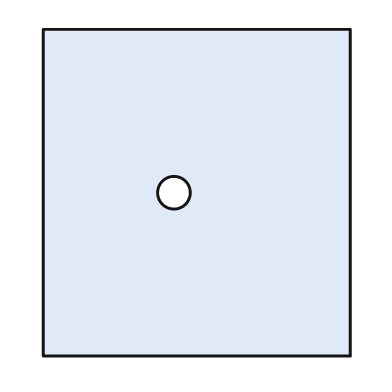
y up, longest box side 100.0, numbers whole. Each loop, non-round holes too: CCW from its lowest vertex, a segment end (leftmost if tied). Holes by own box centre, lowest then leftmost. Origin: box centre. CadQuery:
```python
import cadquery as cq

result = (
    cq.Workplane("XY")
    .moveTo(-47.0, -50.0)
    .lineTo(47.0, -50.0)
    .lineTo(47.0, 50.0)
    .lineTo(-47.0, 50.0)
    .close()
    .moveTo(-7.0, 0.0)
    .circle(5.0)
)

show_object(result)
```